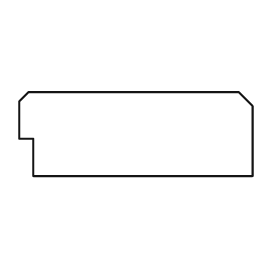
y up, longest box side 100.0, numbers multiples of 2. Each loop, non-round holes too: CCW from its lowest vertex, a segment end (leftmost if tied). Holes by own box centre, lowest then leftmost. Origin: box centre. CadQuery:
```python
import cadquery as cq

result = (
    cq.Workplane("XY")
    .moveTo(-44.0, -18.0)
    .lineTo(50.0, -18.0)
    .lineTo(50.0, 12.0)
    .lineTo(44.0, 18.0)
    .lineTo(-46.0, 18.0)
    .lineTo(-50.0, 14.0)
    .lineTo(-50.0, -2.0)
    .lineTo(-44.0, -2.0)
    .close()
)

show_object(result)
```